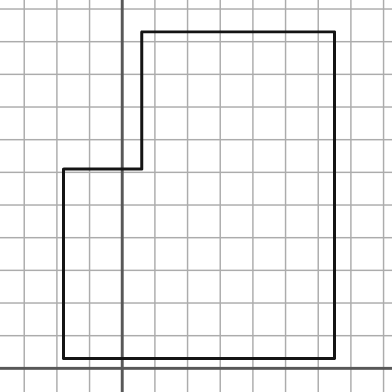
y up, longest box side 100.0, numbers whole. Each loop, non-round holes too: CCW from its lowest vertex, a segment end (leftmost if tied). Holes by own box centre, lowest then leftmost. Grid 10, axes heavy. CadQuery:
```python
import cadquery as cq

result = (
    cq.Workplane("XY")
    .moveTo(-18.0, 3.0)
    .lineTo(65.0, 3.0)
    .lineTo(65.0, 103.0)
    .lineTo(6.0, 103.0)
    .lineTo(6.0, 61.0)
    .lineTo(-18.0, 61.0)
    .close()
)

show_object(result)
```